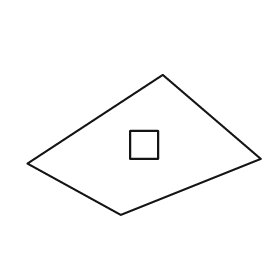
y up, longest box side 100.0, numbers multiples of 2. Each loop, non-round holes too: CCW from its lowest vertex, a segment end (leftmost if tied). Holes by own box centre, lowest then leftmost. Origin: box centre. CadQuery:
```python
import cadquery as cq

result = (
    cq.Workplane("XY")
    .moveTo(-10.0, -30.0)
    .lineTo(50.0, -6.0)
    .lineTo(8.0, 30.0)
    .lineTo(-50.0, -8.0)
    .close()
    .moveTo(-6.0, -6.0)
    .lineTo(6.0, -6.0)
    .lineTo(6.0, 6.0)
    .lineTo(-6.0, 6.0)
    .close()
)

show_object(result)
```